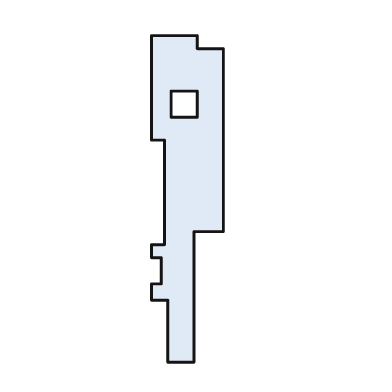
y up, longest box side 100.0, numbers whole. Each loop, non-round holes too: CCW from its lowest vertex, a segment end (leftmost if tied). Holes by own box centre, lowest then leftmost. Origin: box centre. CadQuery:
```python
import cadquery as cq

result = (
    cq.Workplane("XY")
    .moveTo(-6.0, -50.0)
    .lineTo(2.0, -50.0)
    .lineTo(2.0, -10.0)
    .lineTo(11.0, -10.0)
    .lineTo(11.0, 46.0)
    .lineTo(3.0, 46.0)
    .lineTo(3.0, 50.0)
    .lineTo(-11.0, 50.0)
    .lineTo(-11.0, 18.0)
    .lineTo(-7.0, 18.0)
    .lineTo(-7.0, -14.0)
    .lineTo(-11.0, -14.0)
    .lineTo(-11.0, -18.0)
    .lineTo(-8.0, -18.0)
    .lineTo(-8.0, -26.0)
    .lineTo(-11.0, -26.0)
    .lineTo(-11.0, -31.0)
    .lineTo(-6.0, -31.0)
    .close()
    .moveTo(-5.0, 25.0)
    .lineTo(3.0, 25.0)
    .lineTo(3.0, 33.0)
    .lineTo(-5.0, 33.0)
    .close()
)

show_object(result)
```